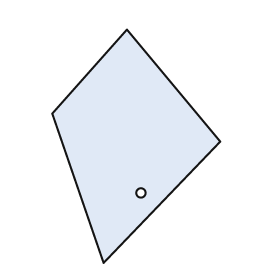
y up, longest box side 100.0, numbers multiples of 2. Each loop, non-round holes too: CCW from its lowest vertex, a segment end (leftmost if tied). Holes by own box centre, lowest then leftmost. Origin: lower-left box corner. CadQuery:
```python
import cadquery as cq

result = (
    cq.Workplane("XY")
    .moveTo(22.0, 0.0)
    .lineTo(72.0, 52.0)
    .lineTo(32.0, 100.0)
    .lineTo(0.0, 64.0)
    .close()
    .moveTo(38.0, 30.0)
    .circle(2.0)
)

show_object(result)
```